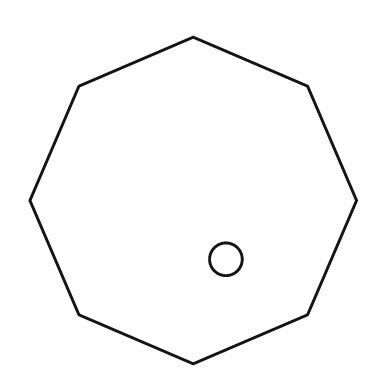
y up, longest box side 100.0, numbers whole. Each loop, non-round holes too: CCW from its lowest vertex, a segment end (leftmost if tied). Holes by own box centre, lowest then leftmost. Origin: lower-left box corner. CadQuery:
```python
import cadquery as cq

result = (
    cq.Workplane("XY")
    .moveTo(50.0, 0.0)
    .lineTo(85.0, 15.0)
    .lineTo(100.0, 50.0)
    .lineTo(85.0, 85.0)
    .lineTo(50.0, 100.0)
    .lineTo(15.0, 85.0)
    .lineTo(0.0, 50.0)
    .lineTo(15.0, 15.0)
    .close()
    .moveTo(60.0, 32.0)
    .circle(5.0)
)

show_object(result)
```